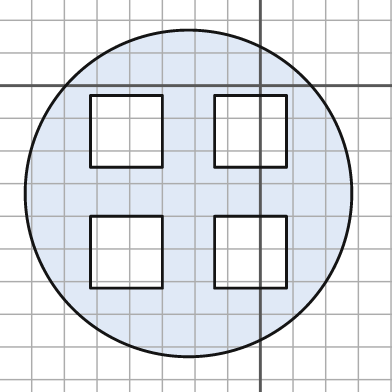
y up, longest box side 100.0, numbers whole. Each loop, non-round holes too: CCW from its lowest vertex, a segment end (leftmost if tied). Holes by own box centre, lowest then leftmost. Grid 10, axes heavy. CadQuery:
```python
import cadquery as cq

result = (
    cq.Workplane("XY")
    .moveTo(-22.0, -33.0)
    .circle(50.0)
    .moveTo(-52.0, -62.0)
    .lineTo(-30.0, -62.0)
    .lineTo(-30.0, -40.0)
    .lineTo(-52.0, -40.0)
    .close()
    .moveTo(-14.0, -62.0)
    .lineTo(8.0, -62.0)
    .lineTo(8.0, -40.0)
    .lineTo(-14.0, -40.0)
    .close()
    .moveTo(-52.0, -25.0)
    .lineTo(-30.0, -25.0)
    .lineTo(-30.0, -3.0)
    .lineTo(-52.0, -3.0)
    .close()
    .moveTo(-14.0, -25.0)
    .lineTo(8.0, -25.0)
    .lineTo(8.0, -3.0)
    .lineTo(-14.0, -3.0)
    .close()
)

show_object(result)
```